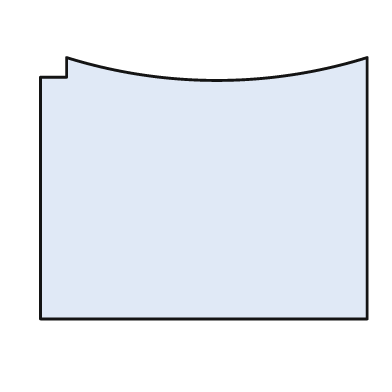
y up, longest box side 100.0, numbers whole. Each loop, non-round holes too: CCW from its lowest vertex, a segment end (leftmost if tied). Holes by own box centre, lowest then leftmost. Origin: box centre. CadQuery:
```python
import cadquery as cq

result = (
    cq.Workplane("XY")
    .moveTo(-50.0, -40.0)
    .lineTo(50.0, -40.0)
    .lineTo(50.0, 40.0)
    .threePointArc((4.0, 33.0), (-42.0, 40.0))
    .lineTo(-42.0, 34.0)
    .lineTo(-50.0, 34.0)
    .close()
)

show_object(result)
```